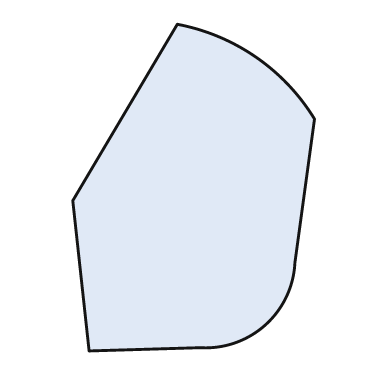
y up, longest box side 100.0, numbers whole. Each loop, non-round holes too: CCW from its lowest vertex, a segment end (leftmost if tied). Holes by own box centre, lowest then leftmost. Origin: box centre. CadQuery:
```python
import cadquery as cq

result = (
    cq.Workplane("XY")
    .moveTo(-32.0, -50.0)
    .lineTo(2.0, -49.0)
    .threePointArc((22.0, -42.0), (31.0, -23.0))
    .lineTo(37.0, 21.0)
    .threePointArc((19.0, 40.0), (-5.0, 50.0))
    .lineTo(-37.0, -4.0)
    .close()
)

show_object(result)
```